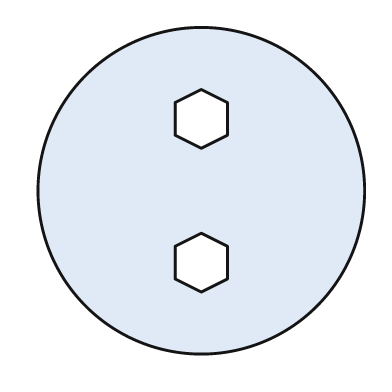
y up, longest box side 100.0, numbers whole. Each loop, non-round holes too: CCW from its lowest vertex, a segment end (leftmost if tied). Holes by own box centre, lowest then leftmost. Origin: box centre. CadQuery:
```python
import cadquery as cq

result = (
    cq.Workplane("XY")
    .moveTo(0.0, 0.0)
    .circle(50.0)
    .moveTo(0.0, -31.0)
    .lineTo(8.0, -27.0)
    .lineTo(8.0, -17.0)
    .lineTo(0.0, -13.0)
    .lineTo(-8.0, -17.0)
    .lineTo(-8.0, -27.0)
    .close()
    .moveTo(0.0, 13.0)
    .lineTo(8.0, 17.0)
    .lineTo(8.0, 27.0)
    .lineTo(0.0, 31.0)
    .lineTo(-8.0, 27.0)
    .lineTo(-8.0, 17.0)
    .close()
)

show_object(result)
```